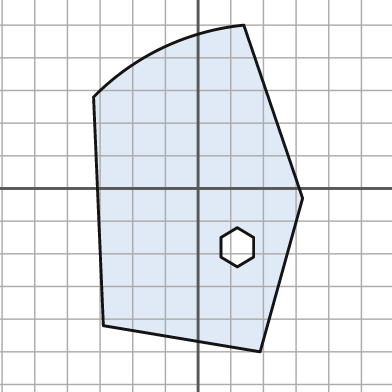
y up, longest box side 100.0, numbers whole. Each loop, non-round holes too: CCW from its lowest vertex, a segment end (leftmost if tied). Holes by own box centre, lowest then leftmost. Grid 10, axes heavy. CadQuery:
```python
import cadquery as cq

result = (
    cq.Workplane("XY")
    .moveTo(19.0, -50.0)
    .lineTo(32.0, -3.0)
    .lineTo(14.0, 50.0)
    .threePointArc((-11.0, 43.0), (-32.0, 28.0))
    .lineTo(-29.0, -42.0)
    .close()
    .moveTo(12.0, -24.0)
    .lineTo(17.0, -21.0)
    .lineTo(17.0, -15.0)
    .lineTo(12.0, -12.0)
    .lineTo(7.0, -15.0)
    .lineTo(7.0, -21.0)
    .close()
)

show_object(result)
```